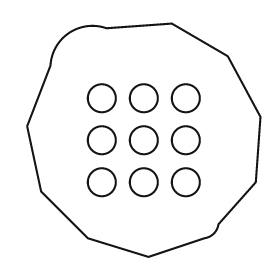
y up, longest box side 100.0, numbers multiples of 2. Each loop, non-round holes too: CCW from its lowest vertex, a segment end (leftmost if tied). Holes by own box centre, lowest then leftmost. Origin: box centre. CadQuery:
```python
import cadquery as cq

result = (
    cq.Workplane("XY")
    .moveTo(2.0, -50.0)
    .lineTo(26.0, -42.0)
    .threePointArc((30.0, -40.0), (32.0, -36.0))
    .lineTo(48.0, -18.0)
    .lineTo(50.0, 10.0)
    .lineTo(36.0, 36.0)
    .lineTo(12.0, 50.0)
    .lineTo(-16.0, 48.0)
    .threePointArc((-32.0, 46.0), (-40.0, 32.0))
    .lineTo(-50.0, 6.0)
    .lineTo(-44.0, -22.0)
    .lineTo(-24.0, -42.0)
    .close()
    .moveTo(-18.0, -18.0)
    .circle(6.0)
    .moveTo(0.0, -18.0)
    .circle(6.0)
    .moveTo(18.0, -18.0)
    .circle(6.0)
    .moveTo(-18.0, 0.0)
    .circle(6.0)
    .moveTo(0.0, 0.0)
    .circle(6.0)
    .moveTo(18.0, 0.0)
    .circle(6.0)
    .moveTo(-18.0, 18.0)
    .circle(6.0)
    .moveTo(0.0, 18.0)
    .circle(6.0)
    .moveTo(18.0, 18.0)
    .circle(6.0)
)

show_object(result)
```